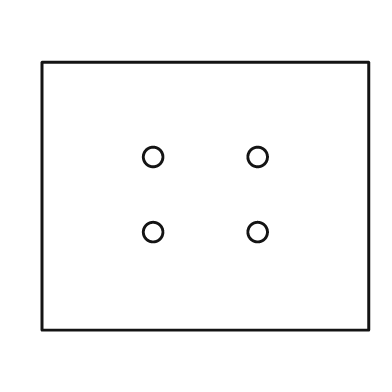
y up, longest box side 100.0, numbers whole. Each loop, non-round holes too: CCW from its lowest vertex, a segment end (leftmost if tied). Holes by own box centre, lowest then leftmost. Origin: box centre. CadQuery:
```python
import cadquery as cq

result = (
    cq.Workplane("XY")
    .moveTo(-50.0, -41.0)
    .lineTo(50.0, -41.0)
    .lineTo(50.0, 41.0)
    .lineTo(-50.0, 41.0)
    .close()
    .moveTo(-16.0, -11.0)
    .circle(3.0)
    .moveTo(16.0, -11.0)
    .circle(3.0)
    .moveTo(-16.0, 12.0)
    .circle(3.0)
    .moveTo(16.0, 12.0)
    .circle(3.0)
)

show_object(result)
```